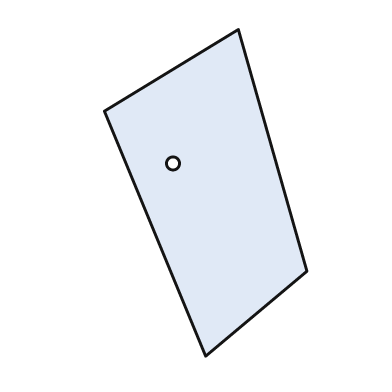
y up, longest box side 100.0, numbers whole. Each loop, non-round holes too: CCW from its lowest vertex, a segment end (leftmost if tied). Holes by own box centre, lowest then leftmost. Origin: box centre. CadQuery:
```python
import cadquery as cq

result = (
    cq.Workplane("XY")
    .moveTo(0.0, -50.0)
    .lineTo(31.0, -24.0)
    .lineTo(10.0, 50.0)
    .lineTo(-31.0, 25.0)
    .close()
    .moveTo(-10.0, 9.0)
    .circle(2.0)
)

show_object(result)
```